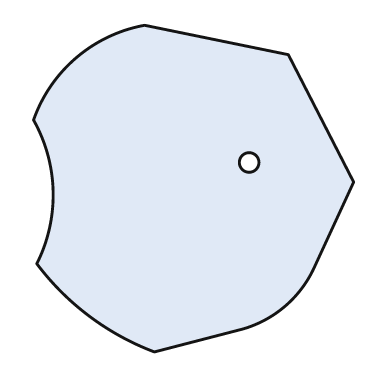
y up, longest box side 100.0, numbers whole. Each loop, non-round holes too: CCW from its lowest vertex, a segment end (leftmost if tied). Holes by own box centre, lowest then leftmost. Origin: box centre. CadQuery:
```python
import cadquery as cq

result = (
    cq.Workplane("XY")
    .moveTo(-12.0, -50.0)
    .lineTo(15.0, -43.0)
    .threePointArc((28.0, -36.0), (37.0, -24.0))
    .lineTo(49.0, 2.0)
    .lineTo(29.0, 41.0)
    .lineTo(-15.0, 50.0)
    .threePointArc((-36.0, 40.0), (-49.0, 21.0))
    .threePointArc((-43.0, -1.0), (-48.0, -23.0))
    .threePointArc((-32.0, -39.0), (-12.0, -50.0))
    .close()
    .moveTo(17.0, 8.0)
    .circle(3.0)
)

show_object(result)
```